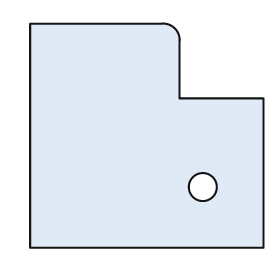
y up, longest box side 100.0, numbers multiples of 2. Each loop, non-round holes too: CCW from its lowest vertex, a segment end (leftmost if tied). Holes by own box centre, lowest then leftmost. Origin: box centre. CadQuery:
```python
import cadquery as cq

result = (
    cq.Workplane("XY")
    .moveTo(-50.0, -48.0)
    .lineTo(50.0, -48.0)
    .lineTo(50.0, 16.0)
    .lineTo(14.0, 16.0)
    .lineTo(14.0, 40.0)
    .threePointArc((12.0, 46.0), (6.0, 48.0))
    .lineTo(-50.0, 48.0)
    .close()
    .moveTo(24.0, -22.0)
    .circle(6.0)
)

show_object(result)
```